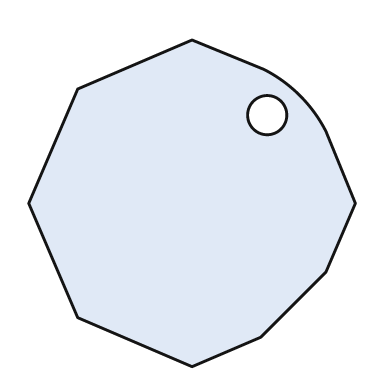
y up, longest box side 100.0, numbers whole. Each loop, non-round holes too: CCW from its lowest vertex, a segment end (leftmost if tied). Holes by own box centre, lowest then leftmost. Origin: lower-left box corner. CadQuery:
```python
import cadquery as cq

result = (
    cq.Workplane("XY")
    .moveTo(50.0, 0.0)
    .lineTo(71.0, 9.0)
    .lineTo(91.0, 29.0)
    .lineTo(100.0, 50.0)
    .lineTo(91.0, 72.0)
    .threePointArc((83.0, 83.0), (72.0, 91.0))
    .lineTo(50.0, 100.0)
    .lineTo(15.0, 85.0)
    .lineTo(0.0, 50.0)
    .lineTo(15.0, 15.0)
    .close()
    .moveTo(73.0, 77.0)
    .circle(6.0)
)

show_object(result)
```